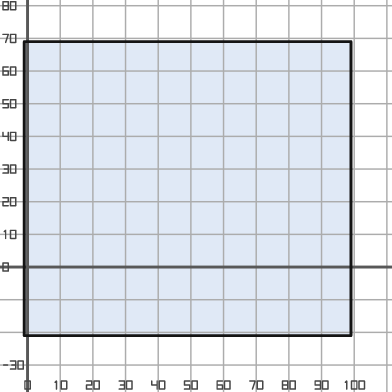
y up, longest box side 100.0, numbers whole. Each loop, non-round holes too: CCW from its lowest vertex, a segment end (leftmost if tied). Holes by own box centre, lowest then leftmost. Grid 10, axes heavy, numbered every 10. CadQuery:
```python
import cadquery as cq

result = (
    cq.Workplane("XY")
    .moveTo(-1.0, -21.0)
    .lineTo(99.0, -21.0)
    .lineTo(99.0, 69.0)
    .lineTo(-1.0, 69.0)
    .close()
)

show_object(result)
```